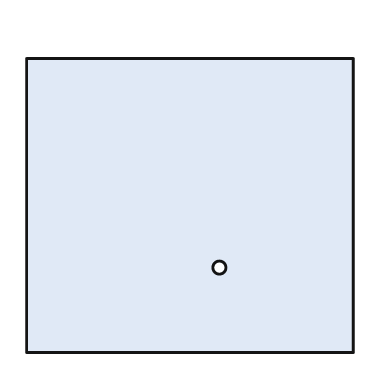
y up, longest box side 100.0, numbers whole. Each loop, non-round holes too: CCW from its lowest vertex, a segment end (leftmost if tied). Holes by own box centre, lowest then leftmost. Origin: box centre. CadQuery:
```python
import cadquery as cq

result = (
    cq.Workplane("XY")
    .moveTo(-50.0, -45.0)
    .lineTo(50.0, -45.0)
    .lineTo(50.0, 45.0)
    .lineTo(-50.0, 45.0)
    .close()
    .moveTo(9.0, -19.0)
    .circle(2.0)
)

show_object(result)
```